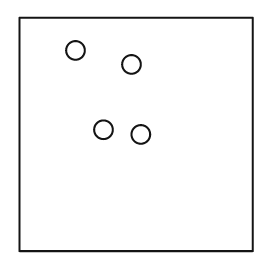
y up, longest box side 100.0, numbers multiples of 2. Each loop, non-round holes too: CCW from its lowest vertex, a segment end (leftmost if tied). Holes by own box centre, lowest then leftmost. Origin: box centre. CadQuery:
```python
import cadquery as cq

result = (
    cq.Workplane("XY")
    .moveTo(-50.0, -50.0)
    .lineTo(50.0, -50.0)
    .lineTo(50.0, 50.0)
    .lineTo(-50.0, 50.0)
    .close()
    .moveTo(2.0, 0.0)
    .circle(4.0)
    .moveTo(-14.0, 2.0)
    .circle(4.0)
    .moveTo(-2.0, 30.0)
    .circle(4.0)
    .moveTo(-26.0, 36.0)
    .circle(4.0)
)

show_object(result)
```